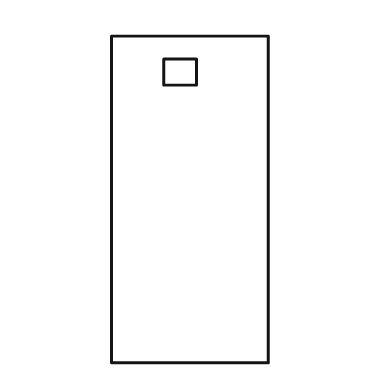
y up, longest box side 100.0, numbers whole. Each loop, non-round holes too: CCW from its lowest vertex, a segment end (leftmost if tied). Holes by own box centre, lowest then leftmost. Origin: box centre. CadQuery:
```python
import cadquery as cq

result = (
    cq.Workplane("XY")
    .moveTo(-24.0, -50.0)
    .lineTo(24.0, -50.0)
    .lineTo(24.0, 50.0)
    .lineTo(-24.0, 50.0)
    .close()
    .moveTo(-8.0, 35.0)
    .lineTo(2.0, 35.0)
    .lineTo(2.0, 43.0)
    .lineTo(-8.0, 43.0)
    .close()
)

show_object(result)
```